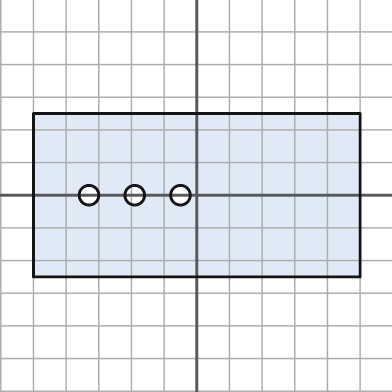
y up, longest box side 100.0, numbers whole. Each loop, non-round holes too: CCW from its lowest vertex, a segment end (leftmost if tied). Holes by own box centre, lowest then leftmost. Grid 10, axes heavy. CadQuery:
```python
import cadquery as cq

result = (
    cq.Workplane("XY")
    .moveTo(-50.0, -25.0)
    .lineTo(50.0, -25.0)
    .lineTo(50.0, 25.0)
    .lineTo(-50.0, 25.0)
    .close()
    .moveTo(-33.0, 0.0)
    .circle(3.0)
    .moveTo(-19.0, 0.0)
    .circle(3.0)
    .moveTo(-5.0, 0.0)
    .circle(3.0)
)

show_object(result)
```